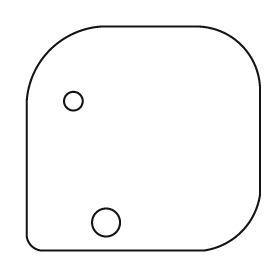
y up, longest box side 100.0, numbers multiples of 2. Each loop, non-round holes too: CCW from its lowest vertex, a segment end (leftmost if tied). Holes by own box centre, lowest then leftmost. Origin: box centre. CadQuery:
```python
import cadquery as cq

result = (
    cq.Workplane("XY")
    .moveTo(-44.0, -48.0)
    .lineTo(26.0, -48.0)
    .threePointArc((42.0, -40.0), (50.0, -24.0))
    .lineTo(50.0, 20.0)
    .threePointArc((42.0, 40.0), (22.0, 48.0))
    .lineTo(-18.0, 48.0)
    .threePointArc((-40.0, 38.0), (-50.0, 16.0))
    .lineTo(-50.0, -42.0)
    .threePointArc((-48.0, -46.0), (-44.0, -48.0))
    .close()
    .moveTo(-16.0, -36.0)
    .circle(6.0)
    .moveTo(-30.0, 16.0)
    .circle(4.0)
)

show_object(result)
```